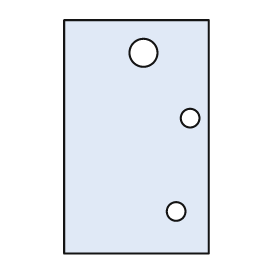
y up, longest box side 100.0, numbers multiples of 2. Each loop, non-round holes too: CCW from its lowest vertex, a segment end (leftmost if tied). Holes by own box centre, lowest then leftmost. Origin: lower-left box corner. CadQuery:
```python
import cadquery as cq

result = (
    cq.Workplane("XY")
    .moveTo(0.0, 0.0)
    .lineTo(62.0, 0.0)
    .lineTo(62.0, 100.0)
    .lineTo(0.0, 100.0)
    .close()
    .moveTo(48.0, 18.0)
    .circle(4.0)
    .moveTo(54.0, 58.0)
    .circle(4.0)
    .moveTo(34.0, 86.0)
    .circle(6.0)
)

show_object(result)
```